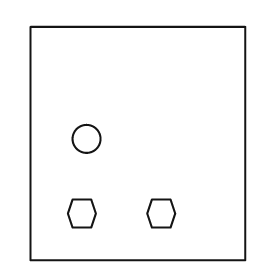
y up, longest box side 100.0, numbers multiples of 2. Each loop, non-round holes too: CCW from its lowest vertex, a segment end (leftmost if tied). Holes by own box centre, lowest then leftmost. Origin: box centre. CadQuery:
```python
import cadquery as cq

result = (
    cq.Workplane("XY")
    .moveTo(-46.0, -50.0)
    .lineTo(46.0, -50.0)
    .lineTo(46.0, 50.0)
    .lineTo(-46.0, 50.0)
    .close()
    .moveTo(-28.0, -36.0)
    .lineTo(-20.0, -36.0)
    .lineTo(-18.0, -30.0)
    .lineTo(-20.0, -24.0)
    .lineTo(-28.0, -24.0)
    .lineTo(-30.0, -30.0)
    .close()
    .moveTo(6.0, -36.0)
    .lineTo(14.0, -36.0)
    .lineTo(16.0, -30.0)
    .lineTo(14.0, -24.0)
    .lineTo(6.0, -24.0)
    .lineTo(4.0, -30.0)
    .close()
    .moveTo(-22.0, 2.0)
    .circle(6.0)
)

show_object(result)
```